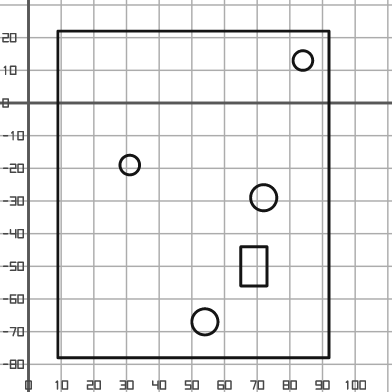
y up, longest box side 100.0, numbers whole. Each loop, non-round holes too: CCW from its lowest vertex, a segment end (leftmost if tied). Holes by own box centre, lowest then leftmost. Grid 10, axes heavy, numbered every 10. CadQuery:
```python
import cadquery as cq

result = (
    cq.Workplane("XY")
    .moveTo(9.0, -78.0)
    .lineTo(92.0, -78.0)
    .lineTo(92.0, 22.0)
    .lineTo(9.0, 22.0)
    .close()
    .moveTo(54.0, -67.0)
    .circle(4.0)
    .moveTo(65.0, -56.0)
    .lineTo(73.0, -56.0)
    .lineTo(73.0, -44.0)
    .lineTo(65.0, -44.0)
    .close()
    .moveTo(72.0, -29.0)
    .circle(4.0)
    .moveTo(31.0, -19.0)
    .circle(3.0)
    .moveTo(84.0, 13.0)
    .circle(3.0)
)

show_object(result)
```